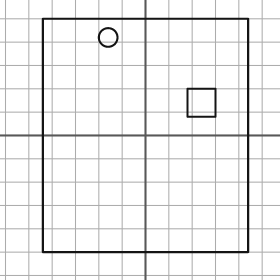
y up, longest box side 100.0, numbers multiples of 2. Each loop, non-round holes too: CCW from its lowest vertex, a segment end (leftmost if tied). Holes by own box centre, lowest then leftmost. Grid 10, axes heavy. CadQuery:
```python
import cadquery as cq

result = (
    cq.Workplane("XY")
    .moveTo(-44.0, -50.0)
    .lineTo(44.0, -50.0)
    .lineTo(44.0, 50.0)
    .lineTo(-44.0, 50.0)
    .close()
    .moveTo(18.0, 8.0)
    .lineTo(30.0, 8.0)
    .lineTo(30.0, 20.0)
    .lineTo(18.0, 20.0)
    .close()
    .moveTo(-16.0, 42.0)
    .circle(4.0)
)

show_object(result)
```